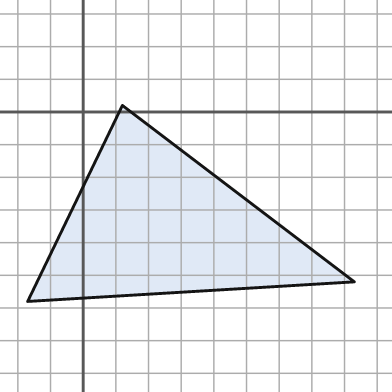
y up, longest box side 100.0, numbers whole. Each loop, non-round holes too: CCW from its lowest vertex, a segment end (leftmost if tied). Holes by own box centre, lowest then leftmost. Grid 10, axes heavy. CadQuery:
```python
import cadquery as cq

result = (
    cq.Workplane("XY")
    .moveTo(-17.0, -58.0)
    .lineTo(83.0, -52.0)
    .lineTo(12.0, 2.0)
    .close()
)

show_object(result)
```